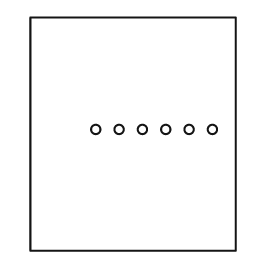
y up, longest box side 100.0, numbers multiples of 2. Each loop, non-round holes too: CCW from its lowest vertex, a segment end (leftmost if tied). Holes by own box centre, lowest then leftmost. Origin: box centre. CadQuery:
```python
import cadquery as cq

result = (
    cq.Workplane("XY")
    .moveTo(-44.0, -50.0)
    .lineTo(44.0, -50.0)
    .lineTo(44.0, 50.0)
    .lineTo(-44.0, 50.0)
    .close()
    .moveTo(-16.0, 2.0)
    .circle(2.0)
    .moveTo(-6.0, 2.0)
    .circle(2.0)
    .moveTo(4.0, 2.0)
    .circle(2.0)
    .moveTo(14.0, 2.0)
    .circle(2.0)
    .moveTo(24.0, 2.0)
    .circle(2.0)
    .moveTo(34.0, 2.0)
    .circle(2.0)
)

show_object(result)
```